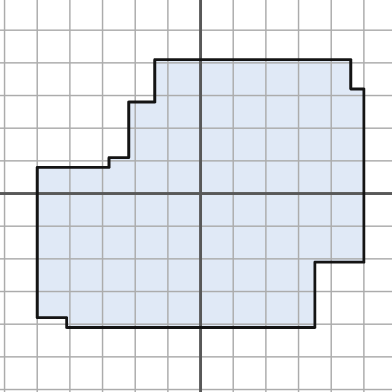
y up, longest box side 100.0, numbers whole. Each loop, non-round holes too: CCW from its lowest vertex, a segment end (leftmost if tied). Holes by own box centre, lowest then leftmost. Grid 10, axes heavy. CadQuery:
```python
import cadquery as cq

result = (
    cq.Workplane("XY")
    .moveTo(-41.0, -41.0)
    .lineTo(35.0, -41.0)
    .lineTo(35.0, -21.0)
    .lineTo(50.0, -21.0)
    .lineTo(50.0, 32.0)
    .lineTo(46.0, 32.0)
    .lineTo(46.0, 41.0)
    .lineTo(-14.0, 41.0)
    .lineTo(-14.0, 28.0)
    .lineTo(-22.0, 28.0)
    .lineTo(-22.0, 11.0)
    .lineTo(-28.0, 11.0)
    .lineTo(-28.0, 8.0)
    .lineTo(-50.0, 8.0)
    .lineTo(-50.0, -38.0)
    .lineTo(-41.0, -38.0)
    .close()
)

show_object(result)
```